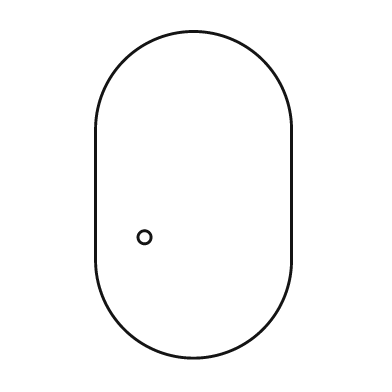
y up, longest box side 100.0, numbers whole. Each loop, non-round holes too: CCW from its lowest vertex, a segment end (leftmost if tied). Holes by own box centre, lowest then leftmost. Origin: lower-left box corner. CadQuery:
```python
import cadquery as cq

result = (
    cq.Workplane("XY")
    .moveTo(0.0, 30.0)
    .threePointArc((30.0, 0.0), (60.0, 30.0))
    .lineTo(60.0, 70.0)
    .threePointArc((30.0, 100.0), (0.0, 70.0))
    .close()
    .moveTo(15.0, 37.0)
    .circle(2.0)
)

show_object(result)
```